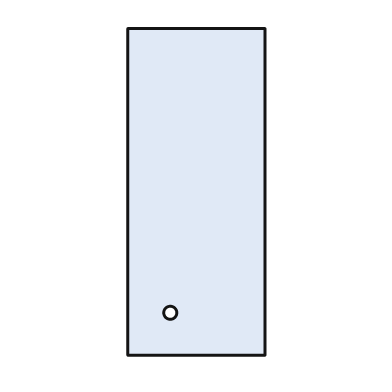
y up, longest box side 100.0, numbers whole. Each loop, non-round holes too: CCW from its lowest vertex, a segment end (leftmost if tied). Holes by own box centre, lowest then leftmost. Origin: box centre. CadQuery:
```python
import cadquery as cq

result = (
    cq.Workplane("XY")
    .moveTo(-21.0, -50.0)
    .lineTo(21.0, -50.0)
    .lineTo(21.0, 50.0)
    .lineTo(-21.0, 50.0)
    .close()
    .moveTo(-8.0, -37.0)
    .circle(2.0)
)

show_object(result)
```